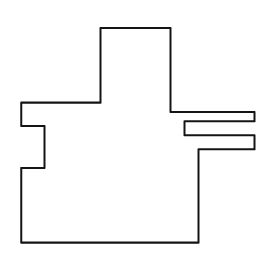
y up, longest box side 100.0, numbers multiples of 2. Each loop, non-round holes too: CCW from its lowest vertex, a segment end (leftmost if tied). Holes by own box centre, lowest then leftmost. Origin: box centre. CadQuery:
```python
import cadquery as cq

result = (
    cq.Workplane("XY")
    .moveTo(-50.0, -46.0)
    .lineTo(26.0, -46.0)
    .lineTo(26.0, -6.0)
    .lineTo(50.0, -6.0)
    .lineTo(50.0, 0.0)
    .lineTo(20.0, 0.0)
    .lineTo(20.0, 6.0)
    .lineTo(50.0, 6.0)
    .lineTo(50.0, 10.0)
    .lineTo(14.0, 10.0)
    .lineTo(14.0, 46.0)
    .lineTo(-16.0, 46.0)
    .lineTo(-16.0, 14.0)
    .lineTo(-50.0, 14.0)
    .lineTo(-50.0, 4.0)
    .lineTo(-40.0, 4.0)
    .lineTo(-40.0, -14.0)
    .lineTo(-50.0, -14.0)
    .close()
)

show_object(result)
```